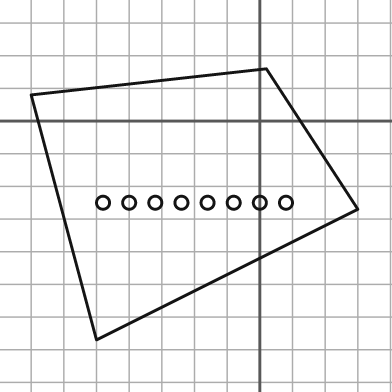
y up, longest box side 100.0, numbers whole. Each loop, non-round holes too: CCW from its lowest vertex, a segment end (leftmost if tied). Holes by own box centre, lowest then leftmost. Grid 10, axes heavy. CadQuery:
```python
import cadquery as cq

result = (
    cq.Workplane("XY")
    .moveTo(-50.0, -67.0)
    .lineTo(30.0, -27.0)
    .lineTo(2.0, 16.0)
    .lineTo(-70.0, 8.0)
    .close()
    .moveTo(-48.0, -25.0)
    .circle(2.0)
    .moveTo(-40.0, -25.0)
    .circle(2.0)
    .moveTo(-32.0, -25.0)
    .circle(2.0)
    .moveTo(-24.0, -25.0)
    .circle(2.0)
    .moveTo(-16.0, -25.0)
    .circle(2.0)
    .moveTo(-8.0, -25.0)
    .circle(2.0)
    .moveTo(0.0, -25.0)
    .circle(2.0)
    .moveTo(8.0, -25.0)
    .circle(2.0)
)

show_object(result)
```